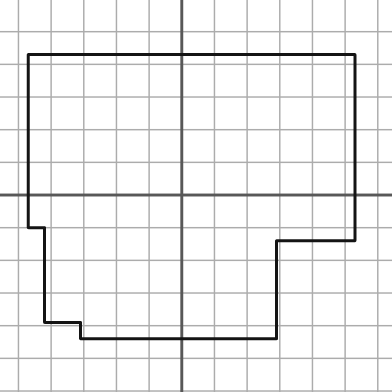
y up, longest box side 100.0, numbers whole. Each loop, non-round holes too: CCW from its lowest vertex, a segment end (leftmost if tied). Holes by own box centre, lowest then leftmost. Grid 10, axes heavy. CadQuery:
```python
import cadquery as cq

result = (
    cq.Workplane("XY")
    .moveTo(-31.0, -44.0)
    .lineTo(29.0, -44.0)
    .lineTo(29.0, -14.0)
    .lineTo(53.0, -14.0)
    .lineTo(53.0, 43.0)
    .lineTo(-47.0, 43.0)
    .lineTo(-47.0, -10.0)
    .lineTo(-42.0, -10.0)
    .lineTo(-42.0, -39.0)
    .lineTo(-31.0, -39.0)
    .close()
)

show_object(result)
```